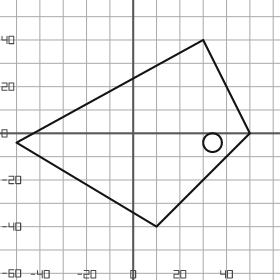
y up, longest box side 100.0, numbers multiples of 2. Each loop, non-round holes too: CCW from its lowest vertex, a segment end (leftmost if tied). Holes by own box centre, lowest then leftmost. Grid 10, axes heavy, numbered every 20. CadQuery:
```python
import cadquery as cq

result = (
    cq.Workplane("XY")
    .moveTo(10.0, -40.0)
    .lineTo(50.0, 0.0)
    .lineTo(30.0, 40.0)
    .lineTo(-50.0, -4.0)
    .close()
    .moveTo(34.0, -4.0)
    .circle(4.0)
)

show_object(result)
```